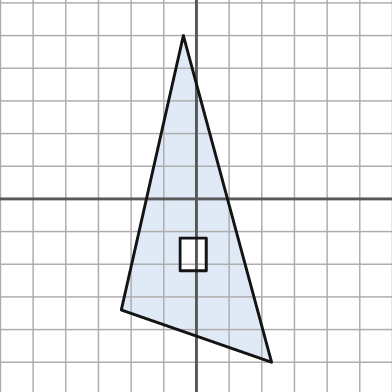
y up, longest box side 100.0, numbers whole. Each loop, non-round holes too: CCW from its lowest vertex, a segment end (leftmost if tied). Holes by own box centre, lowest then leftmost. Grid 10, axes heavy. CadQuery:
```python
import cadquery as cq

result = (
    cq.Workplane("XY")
    .moveTo(23.0, -50.0)
    .lineTo(-4.0, 50.0)
    .lineTo(-23.0, -34.0)
    .close()
    .moveTo(-5.0, -22.0)
    .lineTo(3.0, -22.0)
    .lineTo(3.0, -12.0)
    .lineTo(-5.0, -12.0)
    .close()
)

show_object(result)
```